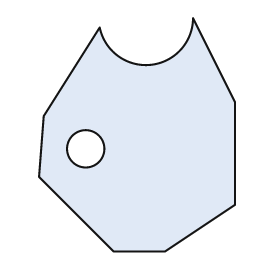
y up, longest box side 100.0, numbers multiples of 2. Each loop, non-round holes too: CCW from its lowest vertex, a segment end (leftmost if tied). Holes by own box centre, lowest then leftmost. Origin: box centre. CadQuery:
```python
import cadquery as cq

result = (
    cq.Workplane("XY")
    .moveTo(-10.0, -50.0)
    .lineTo(12.0, -50.0)
    .lineTo(42.0, -30.0)
    .lineTo(42.0, 14.0)
    .lineTo(24.0, 50.0)
    .threePointArc((6.0, 30.0), (-16.0, 46.0))
    .lineTo(-40.0, 8.0)
    .lineTo(-42.0, -18.0)
    .close()
    .moveTo(-22.0, -6.0)
    .circle(8.0)
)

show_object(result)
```